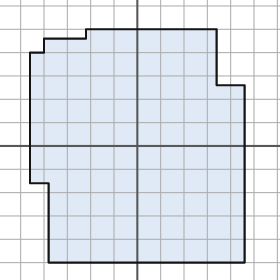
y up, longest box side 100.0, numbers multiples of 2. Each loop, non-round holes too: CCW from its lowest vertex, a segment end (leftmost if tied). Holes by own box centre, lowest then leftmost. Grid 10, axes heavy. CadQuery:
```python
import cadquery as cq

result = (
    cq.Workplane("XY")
    .moveTo(-38.0, -50.0)
    .lineTo(46.0, -50.0)
    .lineTo(46.0, 26.0)
    .lineTo(34.0, 26.0)
    .lineTo(34.0, 50.0)
    .lineTo(-22.0, 50.0)
    .lineTo(-22.0, 46.0)
    .lineTo(-40.0, 46.0)
    .lineTo(-40.0, 40.0)
    .lineTo(-46.0, 40.0)
    .lineTo(-46.0, -16.0)
    .lineTo(-38.0, -16.0)
    .close()
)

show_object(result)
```